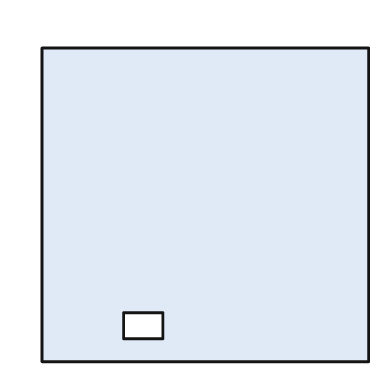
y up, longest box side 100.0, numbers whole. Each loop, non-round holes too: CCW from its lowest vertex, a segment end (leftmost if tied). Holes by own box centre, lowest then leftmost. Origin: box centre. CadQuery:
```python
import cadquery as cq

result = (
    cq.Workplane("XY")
    .moveTo(-50.0, -48.0)
    .lineTo(50.0, -48.0)
    .lineTo(50.0, 48.0)
    .lineTo(-50.0, 48.0)
    .close()
    .moveTo(-25.0, -41.0)
    .lineTo(-13.0, -41.0)
    .lineTo(-13.0, -33.0)
    .lineTo(-25.0, -33.0)
    .close()
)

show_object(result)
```